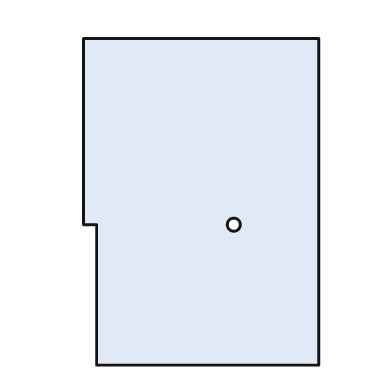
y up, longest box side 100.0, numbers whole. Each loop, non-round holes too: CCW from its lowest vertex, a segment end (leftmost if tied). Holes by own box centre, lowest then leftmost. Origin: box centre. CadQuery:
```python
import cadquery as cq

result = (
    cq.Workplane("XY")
    .moveTo(-32.0, -50.0)
    .lineTo(36.0, -50.0)
    .lineTo(36.0, 50.0)
    .lineTo(-36.0, 50.0)
    .lineTo(-36.0, -7.0)
    .lineTo(-32.0, -7.0)
    .close()
    .moveTo(10.0, -7.0)
    .circle(2.0)
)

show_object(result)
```